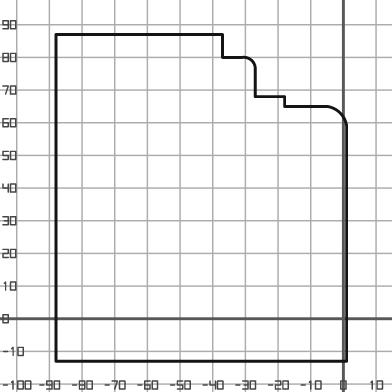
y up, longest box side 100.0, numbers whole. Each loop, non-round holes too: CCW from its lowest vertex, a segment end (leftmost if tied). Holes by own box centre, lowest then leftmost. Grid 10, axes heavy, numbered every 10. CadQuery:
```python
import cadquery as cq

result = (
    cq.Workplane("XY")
    .moveTo(-88.0, -13.0)
    .lineTo(1.0, -13.0)
    .lineTo(1.0, 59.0)
    .threePointArc((-1.0, 63.0), (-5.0, 65.0))
    .lineTo(-18.0, 65.0)
    .lineTo(-18.0, 68.0)
    .lineTo(-27.0, 68.0)
    .lineTo(-27.0, 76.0)
    .threePointArc((-28.0, 79.0), (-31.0, 80.0))
    .lineTo(-37.0, 80.0)
    .lineTo(-37.0, 87.0)
    .lineTo(-88.0, 87.0)
    .close()
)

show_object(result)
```